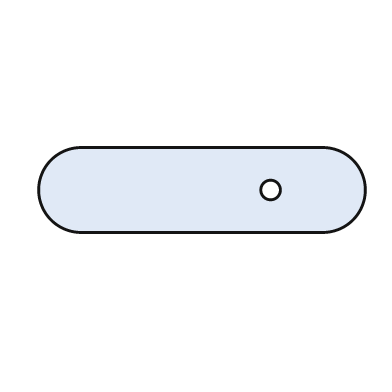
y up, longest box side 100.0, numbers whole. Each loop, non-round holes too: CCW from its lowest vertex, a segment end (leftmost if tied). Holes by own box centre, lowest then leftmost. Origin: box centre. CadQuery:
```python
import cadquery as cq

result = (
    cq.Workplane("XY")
    .moveTo(-37.0, -13.0)
    .lineTo(37.0, -13.0)
    .threePointArc((50.0, 0.0), (37.0, 13.0))
    .lineTo(-37.0, 13.0)
    .threePointArc((-50.0, 0.0), (-37.0, -13.0))
    .close()
    .moveTo(21.0, 0.0)
    .circle(3.0)
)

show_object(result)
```